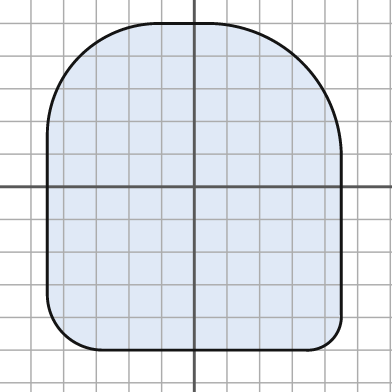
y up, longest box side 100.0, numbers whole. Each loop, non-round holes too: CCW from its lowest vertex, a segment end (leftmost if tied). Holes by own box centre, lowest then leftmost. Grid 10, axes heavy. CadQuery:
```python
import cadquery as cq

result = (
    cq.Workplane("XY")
    .moveTo(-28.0, -50.0)
    .lineTo(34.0, -50.0)
    .threePointArc((42.0, -47.0), (45.0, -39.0))
    .lineTo(45.0, 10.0)
    .threePointArc((33.0, 38.0), (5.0, 50.0))
    .lineTo(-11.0, 50.0)
    .threePointArc((-35.0, 40.0), (-45.0, 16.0))
    .lineTo(-45.0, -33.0)
    .threePointArc((-40.0, -45.0), (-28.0, -50.0))
    .close()
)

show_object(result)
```